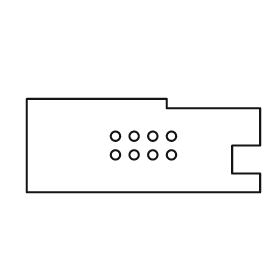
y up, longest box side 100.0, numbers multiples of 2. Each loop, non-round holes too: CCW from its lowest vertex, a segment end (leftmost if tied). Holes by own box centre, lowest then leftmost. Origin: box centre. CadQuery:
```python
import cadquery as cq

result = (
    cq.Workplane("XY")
    .moveTo(-50.0, -20.0)
    .lineTo(50.0, -20.0)
    .lineTo(50.0, -12.0)
    .lineTo(38.0, -12.0)
    .lineTo(38.0, 0.0)
    .lineTo(50.0, 0.0)
    .lineTo(50.0, 16.0)
    .lineTo(10.0, 16.0)
    .lineTo(10.0, 20.0)
    .lineTo(-50.0, 20.0)
    .close()
    .moveTo(-12.0, -4.0)
    .circle(2.0)
    .moveTo(-4.0, -4.0)
    .circle(2.0)
    .moveTo(4.0, -4.0)
    .circle(2.0)
    .moveTo(12.0, -4.0)
    .circle(2.0)
    .moveTo(-12.0, 4.0)
    .circle(2.0)
    .moveTo(-4.0, 4.0)
    .circle(2.0)
    .moveTo(4.0, 4.0)
    .circle(2.0)
    .moveTo(12.0, 4.0)
    .circle(2.0)
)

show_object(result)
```